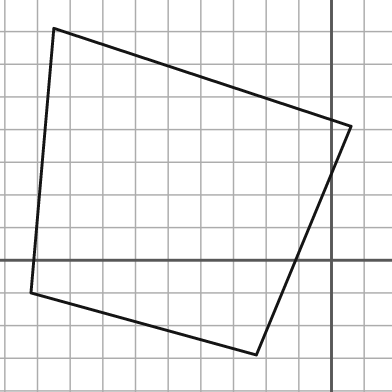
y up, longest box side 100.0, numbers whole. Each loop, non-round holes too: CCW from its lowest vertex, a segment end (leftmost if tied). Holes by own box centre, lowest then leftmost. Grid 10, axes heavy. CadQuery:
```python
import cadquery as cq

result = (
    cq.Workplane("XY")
    .moveTo(-23.0, -29.0)
    .lineTo(6.0, 41.0)
    .lineTo(-85.0, 71.0)
    .lineTo(-92.0, -10.0)
    .close()
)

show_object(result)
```